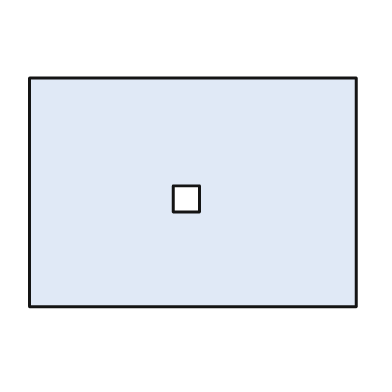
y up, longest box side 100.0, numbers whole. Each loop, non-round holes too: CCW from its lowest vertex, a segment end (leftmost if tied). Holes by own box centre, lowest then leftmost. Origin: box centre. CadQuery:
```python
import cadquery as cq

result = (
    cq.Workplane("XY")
    .moveTo(-50.0, -35.0)
    .lineTo(50.0, -35.0)
    .lineTo(50.0, 35.0)
    .lineTo(-50.0, 35.0)
    .close()
    .moveTo(-6.0, -6.0)
    .lineTo(2.0, -6.0)
    .lineTo(2.0, 2.0)
    .lineTo(-6.0, 2.0)
    .close()
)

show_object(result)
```